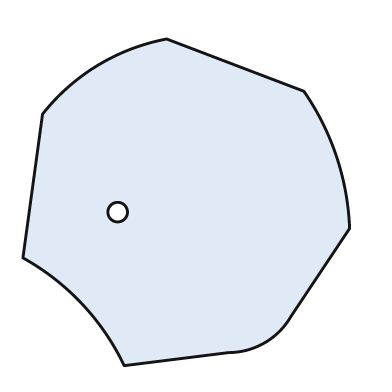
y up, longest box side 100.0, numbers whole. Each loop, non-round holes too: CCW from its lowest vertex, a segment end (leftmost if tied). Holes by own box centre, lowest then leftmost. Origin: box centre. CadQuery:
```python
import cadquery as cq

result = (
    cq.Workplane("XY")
    .moveTo(-19.0, -50.0)
    .lineTo(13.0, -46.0)
    .threePointArc((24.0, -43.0), (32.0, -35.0))
    .lineTo(50.0, -8.0)
    .threePointArc((46.0, 14.0), (36.0, 34.0))
    .lineTo(-6.0, 50.0)
    .threePointArc((-27.0, 42.0), (-44.0, 27.0))
    .lineTo(-50.0, -17.0)
    .threePointArc((-32.0, -31.0), (-19.0, -50.0))
    .close()
    .moveTo(-21.0, -3.0)
    .circle(3.0)
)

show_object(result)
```